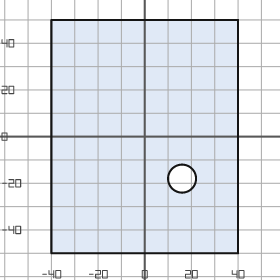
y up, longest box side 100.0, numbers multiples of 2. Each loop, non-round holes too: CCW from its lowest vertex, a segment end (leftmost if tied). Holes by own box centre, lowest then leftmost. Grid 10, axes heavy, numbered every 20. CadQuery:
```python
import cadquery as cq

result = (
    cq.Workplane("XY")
    .moveTo(-40.0, -50.0)
    .lineTo(40.0, -50.0)
    .lineTo(40.0, 50.0)
    .lineTo(-40.0, 50.0)
    .close()
    .moveTo(16.0, -18.0)
    .circle(6.0)
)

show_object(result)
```